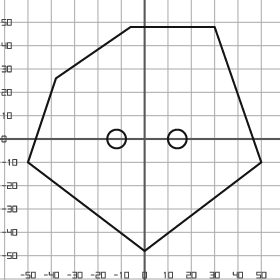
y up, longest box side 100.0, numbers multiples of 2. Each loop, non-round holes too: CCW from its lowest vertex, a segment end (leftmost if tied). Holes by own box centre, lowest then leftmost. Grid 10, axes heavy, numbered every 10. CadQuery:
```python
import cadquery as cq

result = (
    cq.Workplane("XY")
    .moveTo(0.0, -48.0)
    .lineTo(50.0, -10.0)
    .lineTo(30.0, 48.0)
    .lineTo(-6.0, 48.0)
    .lineTo(-38.0, 26.0)
    .lineTo(-50.0, -10.0)
    .close()
    .moveTo(-12.0, 0.0)
    .circle(4.0)
    .moveTo(14.0, 0.0)
    .circle(4.0)
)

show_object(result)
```